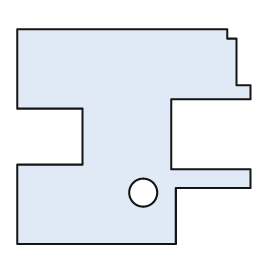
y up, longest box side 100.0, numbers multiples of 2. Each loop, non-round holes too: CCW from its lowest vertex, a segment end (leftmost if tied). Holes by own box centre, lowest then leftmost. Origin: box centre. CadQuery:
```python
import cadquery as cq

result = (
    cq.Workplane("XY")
    .moveTo(-50.0, -46.0)
    .lineTo(18.0, -46.0)
    .lineTo(18.0, -22.0)
    .lineTo(50.0, -22.0)
    .lineTo(50.0, -14.0)
    .lineTo(16.0, -14.0)
    .lineTo(16.0, 16.0)
    .lineTo(50.0, 16.0)
    .lineTo(50.0, 22.0)
    .lineTo(44.0, 22.0)
    .lineTo(44.0, 42.0)
    .lineTo(40.0, 42.0)
    .lineTo(40.0, 46.0)
    .lineTo(-50.0, 46.0)
    .lineTo(-50.0, 12.0)
    .lineTo(-22.0, 12.0)
    .lineTo(-22.0, -12.0)
    .lineTo(-50.0, -12.0)
    .close()
    .moveTo(4.0, -24.0)
    .circle(6.0)
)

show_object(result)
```